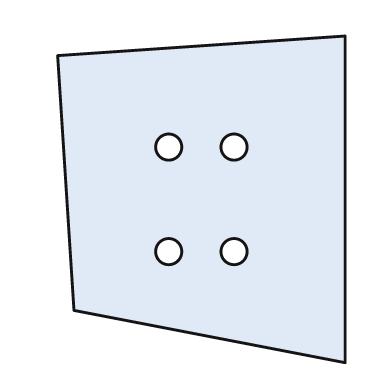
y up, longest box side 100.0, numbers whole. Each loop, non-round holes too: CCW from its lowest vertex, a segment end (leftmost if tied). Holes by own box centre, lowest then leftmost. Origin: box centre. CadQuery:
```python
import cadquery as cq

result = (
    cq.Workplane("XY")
    .moveTo(44.0, -50.0)
    .lineTo(44.0, 50.0)
    .lineTo(-44.0, 44.0)
    .lineTo(-39.0, -34.0)
    .close()
    .moveTo(-10.0, -16.0)
    .circle(4.0)
    .moveTo(10.0, -16.0)
    .circle(4.0)
    .moveTo(-10.0, 16.0)
    .circle(4.0)
    .moveTo(10.0, 16.0)
    .circle(4.0)
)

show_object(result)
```